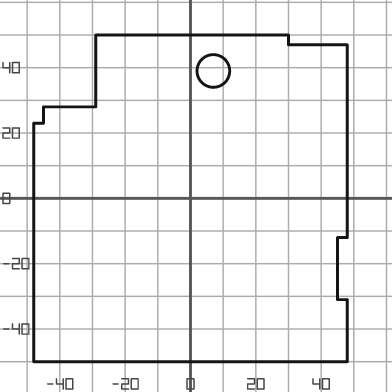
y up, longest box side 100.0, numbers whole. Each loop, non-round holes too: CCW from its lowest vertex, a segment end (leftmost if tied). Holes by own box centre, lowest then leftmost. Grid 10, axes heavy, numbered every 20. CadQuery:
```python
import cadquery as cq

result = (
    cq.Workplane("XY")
    .moveTo(-48.0, -50.0)
    .lineTo(48.0, -50.0)
    .lineTo(48.0, -31.0)
    .lineTo(45.0, -31.0)
    .lineTo(45.0, -12.0)
    .lineTo(48.0, -12.0)
    .lineTo(48.0, 47.0)
    .lineTo(30.0, 47.0)
    .lineTo(30.0, 50.0)
    .lineTo(-29.0, 50.0)
    .lineTo(-29.0, 28.0)
    .lineTo(-45.0, 28.0)
    .lineTo(-45.0, 23.0)
    .lineTo(-48.0, 23.0)
    .close()
    .moveTo(7.0, 39.0)
    .circle(5.0)
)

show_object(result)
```